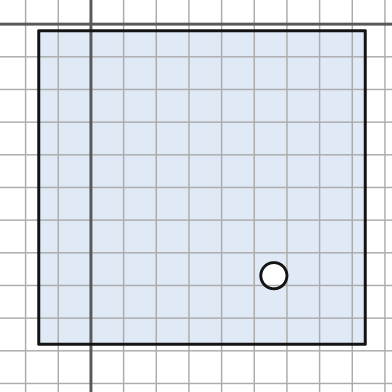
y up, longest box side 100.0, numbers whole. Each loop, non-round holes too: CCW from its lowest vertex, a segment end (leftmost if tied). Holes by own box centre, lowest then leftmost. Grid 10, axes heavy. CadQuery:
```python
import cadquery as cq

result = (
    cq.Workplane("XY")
    .moveTo(-16.0, -98.0)
    .lineTo(84.0, -98.0)
    .lineTo(84.0, -2.0)
    .lineTo(-16.0, -2.0)
    .close()
    .moveTo(56.0, -77.0)
    .circle(4.0)
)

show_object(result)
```